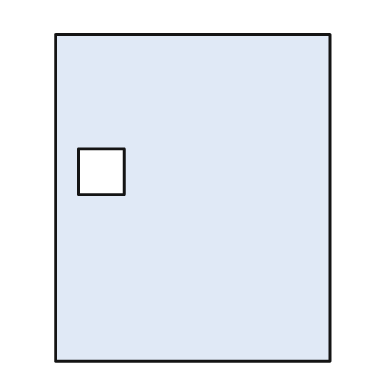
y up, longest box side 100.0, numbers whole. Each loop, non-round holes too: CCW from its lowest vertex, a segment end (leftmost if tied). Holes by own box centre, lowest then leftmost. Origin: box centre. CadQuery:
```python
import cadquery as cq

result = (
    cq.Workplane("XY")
    .moveTo(-42.0, -50.0)
    .lineTo(42.0, -50.0)
    .lineTo(42.0, 50.0)
    .lineTo(-42.0, 50.0)
    .close()
    .moveTo(-35.0, 1.0)
    .lineTo(-21.0, 1.0)
    .lineTo(-21.0, 15.0)
    .lineTo(-35.0, 15.0)
    .close()
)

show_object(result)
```